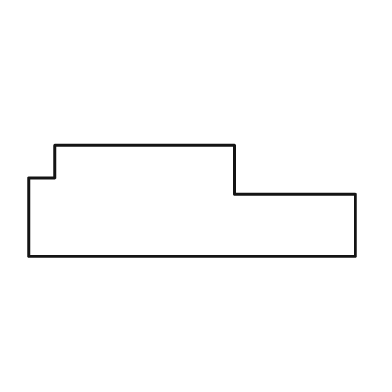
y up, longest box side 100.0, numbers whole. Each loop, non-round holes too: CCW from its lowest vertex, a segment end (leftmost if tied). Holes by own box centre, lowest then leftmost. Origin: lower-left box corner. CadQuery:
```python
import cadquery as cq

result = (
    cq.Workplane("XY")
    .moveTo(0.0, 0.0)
    .lineTo(100.0, 0.0)
    .lineTo(100.0, 19.0)
    .lineTo(63.0, 19.0)
    .lineTo(63.0, 34.0)
    .lineTo(8.0, 34.0)
    .lineTo(8.0, 24.0)
    .lineTo(0.0, 24.0)
    .close()
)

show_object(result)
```